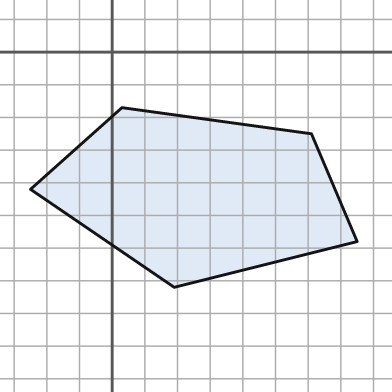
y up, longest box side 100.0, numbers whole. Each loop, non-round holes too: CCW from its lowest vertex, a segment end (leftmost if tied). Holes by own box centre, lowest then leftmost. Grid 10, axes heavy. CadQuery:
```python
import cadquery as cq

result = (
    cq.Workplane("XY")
    .moveTo(19.0, -72.0)
    .lineTo(75.0, -58.0)
    .lineTo(61.0, -25.0)
    .lineTo(3.0, -17.0)
    .lineTo(-25.0, -42.0)
    .close()
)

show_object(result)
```